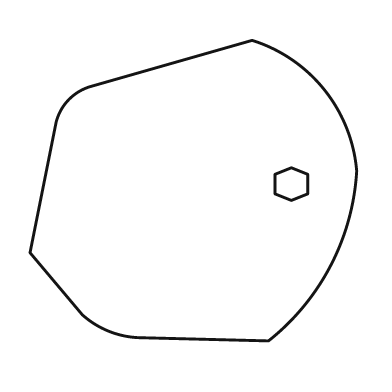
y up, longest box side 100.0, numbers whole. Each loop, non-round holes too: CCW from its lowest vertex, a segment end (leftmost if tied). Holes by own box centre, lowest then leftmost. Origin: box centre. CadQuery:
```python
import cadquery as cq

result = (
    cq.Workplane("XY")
    .moveTo(23.0, -46.0)
    .threePointArc((42.0, -23.0), (50.0, 6.0))
    .threePointArc((40.0, 31.0), (18.0, 46.0))
    .lineTo(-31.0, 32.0)
    .threePointArc((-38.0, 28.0), (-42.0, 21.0))
    .lineTo(-50.0, -19.0)
    .lineTo(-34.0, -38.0)
    .threePointArc((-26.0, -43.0), (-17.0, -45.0))
    .close()
    .moveTo(30.0, -3.0)
    .lineTo(35.0, -1.0)
    .lineTo(35.0, 5.0)
    .lineTo(30.0, 7.0)
    .lineTo(25.0, 5.0)
    .lineTo(25.0, -1.0)
    .close()
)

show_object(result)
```